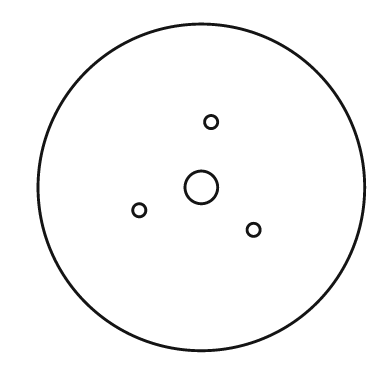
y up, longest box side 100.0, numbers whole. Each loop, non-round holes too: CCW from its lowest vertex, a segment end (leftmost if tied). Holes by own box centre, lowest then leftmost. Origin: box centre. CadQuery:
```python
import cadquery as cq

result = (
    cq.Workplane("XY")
    .moveTo(0.0, 0.0)
    .circle(50.0)
    .moveTo(16.0, -13.0)
    .circle(2.0)
    .moveTo(-19.0, -7.0)
    .circle(2.0)
    .moveTo(0.0, 0.0)
    .circle(5.0)
    .moveTo(3.0, 20.0)
    .circle(2.0)
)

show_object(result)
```